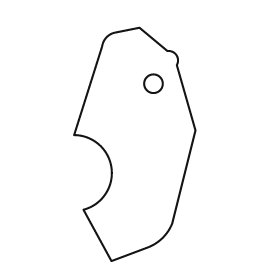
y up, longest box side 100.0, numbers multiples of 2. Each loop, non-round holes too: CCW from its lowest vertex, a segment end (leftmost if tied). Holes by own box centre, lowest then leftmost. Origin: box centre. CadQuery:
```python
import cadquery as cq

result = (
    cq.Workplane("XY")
    .moveTo(-10.0, -50.0)
    .lineTo(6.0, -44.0)
    .threePointArc((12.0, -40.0), (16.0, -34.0))
    .lineTo(26.0, 6.0)
    .lineTo(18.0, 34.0)
    .threePointArc((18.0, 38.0), (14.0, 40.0))
    .lineTo(2.0, 50.0)
    .lineTo(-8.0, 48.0)
    .threePointArc((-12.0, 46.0), (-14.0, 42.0))
    .lineTo(-26.0, 4.0)
    .threePointArc((-10.0, -10.0), (-22.0, -28.0))
    .close()
    .moveTo(8.0, 26.0)
    .circle(4.0)
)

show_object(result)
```